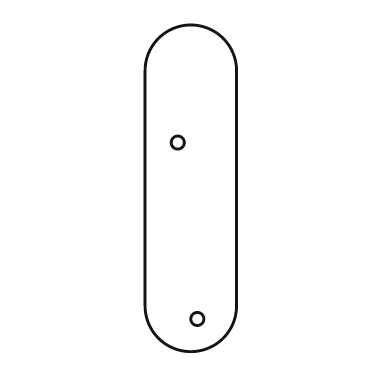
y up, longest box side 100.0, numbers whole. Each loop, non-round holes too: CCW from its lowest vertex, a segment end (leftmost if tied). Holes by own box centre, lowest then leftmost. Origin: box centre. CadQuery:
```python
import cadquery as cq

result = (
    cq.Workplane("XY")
    .moveTo(-14.0, -36.0)
    .threePointArc((0.0, -50.0), (14.0, -36.0))
    .lineTo(14.0, 36.0)
    .threePointArc((0.0, 50.0), (-14.0, 36.0))
    .close()
    .moveTo(2.0, -40.0)
    .circle(2.0)
    .moveTo(-4.0, 14.0)
    .circle(2.0)
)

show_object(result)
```